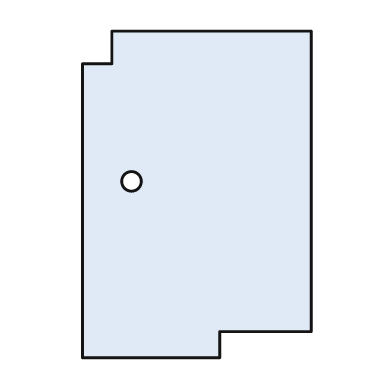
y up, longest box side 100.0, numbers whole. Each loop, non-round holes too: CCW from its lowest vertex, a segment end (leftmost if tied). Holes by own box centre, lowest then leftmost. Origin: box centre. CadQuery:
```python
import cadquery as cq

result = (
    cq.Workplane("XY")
    .moveTo(-35.0, -50.0)
    .lineTo(7.0, -50.0)
    .lineTo(7.0, -42.0)
    .lineTo(35.0, -42.0)
    .lineTo(35.0, 50.0)
    .lineTo(-26.0, 50.0)
    .lineTo(-26.0, 40.0)
    .lineTo(-35.0, 40.0)
    .close()
    .moveTo(-20.0, 4.0)
    .circle(3.0)
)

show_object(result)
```